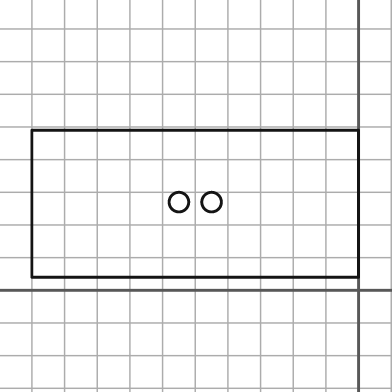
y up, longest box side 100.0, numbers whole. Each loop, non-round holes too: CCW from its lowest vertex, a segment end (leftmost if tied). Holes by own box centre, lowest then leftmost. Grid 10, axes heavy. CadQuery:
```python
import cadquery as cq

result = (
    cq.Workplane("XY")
    .moveTo(-100.0, 4.0)
    .lineTo(0.0, 4.0)
    .lineTo(0.0, 49.0)
    .lineTo(-100.0, 49.0)
    .close()
    .moveTo(-55.0, 27.0)
    .circle(3.0)
    .moveTo(-45.0, 27.0)
    .circle(3.0)
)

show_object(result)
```